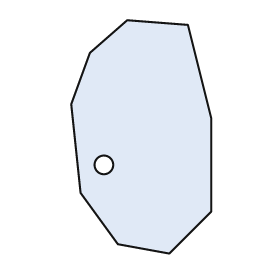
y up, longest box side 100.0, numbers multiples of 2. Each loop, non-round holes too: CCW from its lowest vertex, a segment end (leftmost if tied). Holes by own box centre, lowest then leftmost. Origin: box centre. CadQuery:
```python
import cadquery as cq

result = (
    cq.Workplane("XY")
    .moveTo(12.0, -50.0)
    .lineTo(30.0, -32.0)
    .lineTo(30.0, 8.0)
    .lineTo(20.0, 48.0)
    .lineTo(-6.0, 50.0)
    .lineTo(-22.0, 36.0)
    .lineTo(-30.0, 14.0)
    .lineTo(-26.0, -24.0)
    .lineTo(-10.0, -46.0)
    .close()
    .moveTo(-16.0, -12.0)
    .circle(4.0)
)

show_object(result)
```